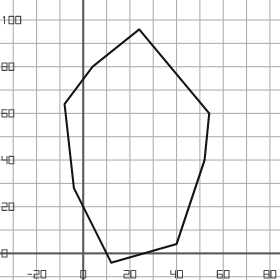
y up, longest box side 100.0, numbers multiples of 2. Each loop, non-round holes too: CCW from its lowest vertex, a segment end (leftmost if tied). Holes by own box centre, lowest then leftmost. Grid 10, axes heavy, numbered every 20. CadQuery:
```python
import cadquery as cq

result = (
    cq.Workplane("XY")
    .moveTo(12.0, -4.0)
    .lineTo(40.0, 4.0)
    .lineTo(52.0, 40.0)
    .lineTo(54.0, 60.0)
    .lineTo(24.0, 96.0)
    .lineTo(4.0, 80.0)
    .lineTo(-8.0, 64.0)
    .lineTo(-4.0, 28.0)
    .close()
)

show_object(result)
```